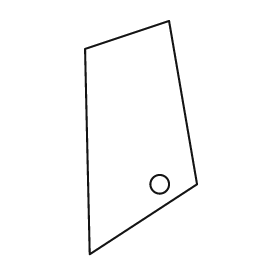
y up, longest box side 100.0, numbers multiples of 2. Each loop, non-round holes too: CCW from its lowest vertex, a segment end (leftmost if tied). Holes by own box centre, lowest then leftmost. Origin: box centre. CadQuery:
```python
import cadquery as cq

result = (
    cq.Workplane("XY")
    .moveTo(-22.0, -50.0)
    .lineTo(24.0, -20.0)
    .lineTo(12.0, 50.0)
    .lineTo(-24.0, 38.0)
    .close()
    .moveTo(8.0, -20.0)
    .circle(4.0)
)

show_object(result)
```